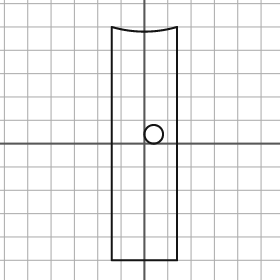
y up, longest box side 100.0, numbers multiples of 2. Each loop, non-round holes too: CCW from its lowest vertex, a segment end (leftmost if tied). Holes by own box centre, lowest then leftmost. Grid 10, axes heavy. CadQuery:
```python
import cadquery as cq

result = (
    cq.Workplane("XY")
    .moveTo(-14.0, -50.0)
    .lineTo(14.0, -50.0)
    .lineTo(14.0, 50.0)
    .threePointArc((0.0, 48.0), (-14.0, 50.0))
    .close()
    .moveTo(4.0, 4.0)
    .circle(4.0)
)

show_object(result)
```